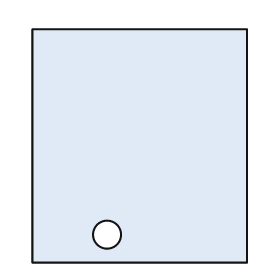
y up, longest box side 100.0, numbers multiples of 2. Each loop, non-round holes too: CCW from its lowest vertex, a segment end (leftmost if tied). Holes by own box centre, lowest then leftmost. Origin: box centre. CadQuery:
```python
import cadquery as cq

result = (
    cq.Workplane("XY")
    .moveTo(-46.0, -50.0)
    .lineTo(46.0, -50.0)
    .lineTo(46.0, 50.0)
    .lineTo(-46.0, 50.0)
    .close()
    .moveTo(-14.0, -38.0)
    .circle(6.0)
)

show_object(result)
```